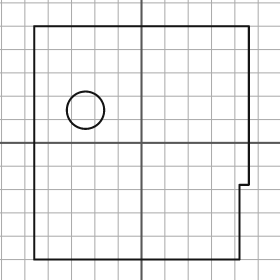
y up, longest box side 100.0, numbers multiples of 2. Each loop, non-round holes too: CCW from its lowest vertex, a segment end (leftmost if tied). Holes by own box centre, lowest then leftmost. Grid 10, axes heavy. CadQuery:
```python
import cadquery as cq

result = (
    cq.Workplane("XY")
    .moveTo(-46.0, -50.0)
    .lineTo(42.0, -50.0)
    .lineTo(42.0, -18.0)
    .lineTo(46.0, -18.0)
    .lineTo(46.0, 50.0)
    .lineTo(-46.0, 50.0)
    .close()
    .moveTo(-24.0, 14.0)
    .circle(8.0)
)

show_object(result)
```